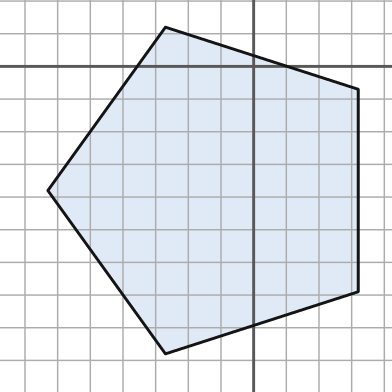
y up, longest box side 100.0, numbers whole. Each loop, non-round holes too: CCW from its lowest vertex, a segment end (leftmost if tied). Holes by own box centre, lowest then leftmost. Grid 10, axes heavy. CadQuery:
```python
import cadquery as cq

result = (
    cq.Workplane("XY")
    .moveTo(-27.0, -88.0)
    .lineTo(32.0, -69.0)
    .lineTo(32.0, -7.0)
    .lineTo(-27.0, 12.0)
    .lineTo(-63.0, -38.0)
    .close()
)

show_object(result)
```